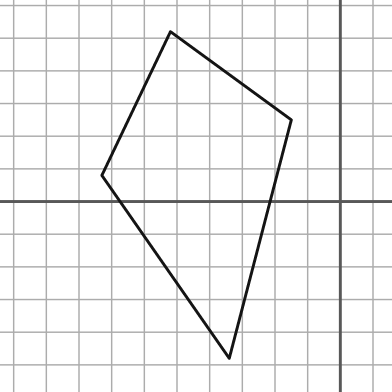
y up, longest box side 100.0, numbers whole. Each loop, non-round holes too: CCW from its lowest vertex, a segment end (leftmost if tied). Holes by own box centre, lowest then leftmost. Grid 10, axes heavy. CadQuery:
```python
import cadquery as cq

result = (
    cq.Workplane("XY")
    .moveTo(-34.0, -48.0)
    .lineTo(-15.0, 25.0)
    .lineTo(-52.0, 52.0)
    .lineTo(-73.0, 8.0)
    .close()
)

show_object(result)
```